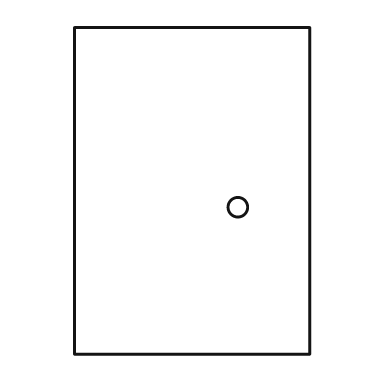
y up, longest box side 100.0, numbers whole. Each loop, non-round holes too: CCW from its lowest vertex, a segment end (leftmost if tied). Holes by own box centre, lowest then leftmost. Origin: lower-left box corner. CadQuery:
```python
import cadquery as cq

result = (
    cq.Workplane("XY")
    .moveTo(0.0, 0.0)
    .lineTo(72.0, 0.0)
    .lineTo(72.0, 100.0)
    .lineTo(0.0, 100.0)
    .close()
    .moveTo(50.0, 45.0)
    .circle(3.0)
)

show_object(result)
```